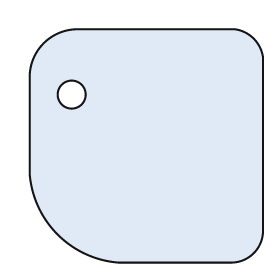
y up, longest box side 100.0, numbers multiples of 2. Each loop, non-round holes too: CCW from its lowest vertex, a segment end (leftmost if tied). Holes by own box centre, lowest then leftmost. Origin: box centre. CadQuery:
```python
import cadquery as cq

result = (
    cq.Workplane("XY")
    .moveTo(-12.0, -50.0)
    .lineTo(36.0, -50.0)
    .threePointArc((46.0, -46.0), (50.0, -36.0))
    .lineTo(50.0, 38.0)
    .threePointArc((46.0, 46.0), (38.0, 50.0))
    .lineTo(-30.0, 50.0)
    .threePointArc((-44.0, 44.0), (-50.0, 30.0))
    .lineTo(-50.0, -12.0)
    .threePointArc((-38.0, -38.0), (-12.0, -50.0))
    .close()
    .moveTo(-32.0, 22.0)
    .circle(6.0)
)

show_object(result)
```